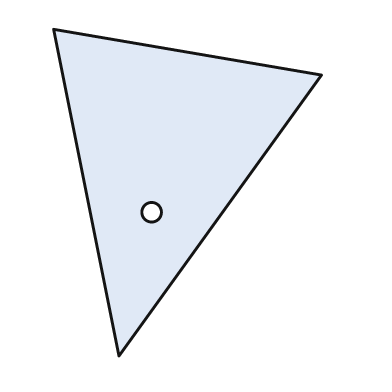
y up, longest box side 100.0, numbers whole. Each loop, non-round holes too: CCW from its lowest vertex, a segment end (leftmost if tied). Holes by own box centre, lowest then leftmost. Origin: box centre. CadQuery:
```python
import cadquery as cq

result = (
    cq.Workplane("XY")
    .moveTo(-21.0, -50.0)
    .lineTo(41.0, 36.0)
    .lineTo(-41.0, 50.0)
    .close()
    .moveTo(-11.0, -6.0)
    .circle(3.0)
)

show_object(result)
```